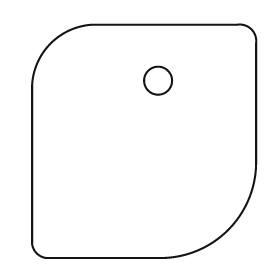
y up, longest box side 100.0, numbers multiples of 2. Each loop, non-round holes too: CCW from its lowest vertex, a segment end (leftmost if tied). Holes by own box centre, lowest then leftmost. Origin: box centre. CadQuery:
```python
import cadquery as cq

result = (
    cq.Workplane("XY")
    .moveTo(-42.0, -50.0)
    .lineTo(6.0, -50.0)
    .threePointArc((36.0, -38.0), (48.0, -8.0))
    .lineTo(48.0, 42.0)
    .threePointArc((46.0, 48.0), (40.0, 50.0))
    .lineTo(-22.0, 50.0)
    .threePointArc((-40.0, 42.0), (-48.0, 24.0))
    .lineTo(-48.0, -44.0)
    .threePointArc((-46.0, -48.0), (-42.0, -50.0))
    .close()
    .moveTo(6.0, 26.0)
    .circle(6.0)
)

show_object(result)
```